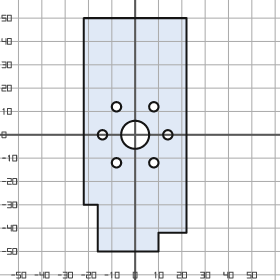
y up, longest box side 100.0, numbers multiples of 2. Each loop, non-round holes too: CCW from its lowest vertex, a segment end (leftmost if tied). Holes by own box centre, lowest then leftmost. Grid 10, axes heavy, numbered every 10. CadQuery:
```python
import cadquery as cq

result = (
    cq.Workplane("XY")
    .moveTo(-16.0, -50.0)
    .lineTo(10.0, -50.0)
    .lineTo(10.0, -42.0)
    .lineTo(22.0, -42.0)
    .lineTo(22.0, 50.0)
    .lineTo(-22.0, 50.0)
    .lineTo(-22.0, -30.0)
    .lineTo(-16.0, -30.0)
    .close()
    .moveTo(-8.0, -12.0)
    .circle(2.0)
    .moveTo(8.0, -12.0)
    .circle(2.0)
    .moveTo(-14.0, 0.0)
    .circle(2.0)
    .moveTo(0.0, 0.0)
    .circle(6.0)
    .moveTo(14.0, 0.0)
    .circle(2.0)
    .moveTo(-8.0, 12.0)
    .circle(2.0)
    .moveTo(8.0, 12.0)
    .circle(2.0)
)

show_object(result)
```